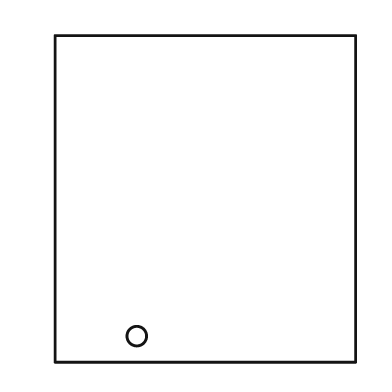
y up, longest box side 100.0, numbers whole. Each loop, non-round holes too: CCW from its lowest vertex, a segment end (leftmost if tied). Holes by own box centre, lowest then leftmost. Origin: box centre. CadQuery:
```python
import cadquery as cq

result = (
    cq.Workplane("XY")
    .moveTo(-46.0, -50.0)
    .lineTo(46.0, -50.0)
    .lineTo(46.0, 50.0)
    .lineTo(-46.0, 50.0)
    .close()
    .moveTo(-21.0, -42.0)
    .circle(3.0)
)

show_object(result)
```